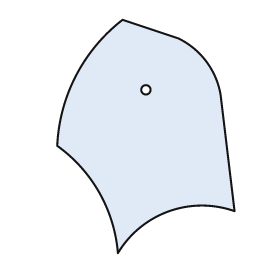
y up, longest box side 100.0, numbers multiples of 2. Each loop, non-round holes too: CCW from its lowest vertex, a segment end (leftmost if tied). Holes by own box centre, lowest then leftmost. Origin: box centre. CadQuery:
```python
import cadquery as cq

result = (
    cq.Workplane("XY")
    .moveTo(-12.0, -50.0)
    .threePointArc((10.0, -32.0), (38.0, -32.0))
    .lineTo(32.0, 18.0)
    .threePointArc((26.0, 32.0), (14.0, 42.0))
    .lineTo(-10.0, 50.0)
    .threePointArc((-30.0, 26.0), (-38.0, -4.0))
    .threePointArc((-20.0, -24.0), (-12.0, -50.0))
    .close()
    .moveTo(0.0, 20.0)
    .circle(2.0)
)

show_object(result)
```